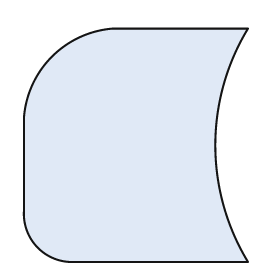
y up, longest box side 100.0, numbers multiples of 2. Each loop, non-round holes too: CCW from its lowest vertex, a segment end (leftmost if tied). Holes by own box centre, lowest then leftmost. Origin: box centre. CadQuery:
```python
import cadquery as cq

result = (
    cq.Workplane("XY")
    .moveTo(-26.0, -50.0)
    .lineTo(48.0, -50.0)
    .threePointArc((34.0, 0.0), (48.0, 50.0))
    .lineTo(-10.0, 50.0)
    .threePointArc((-36.0, 38.0), (-48.0, 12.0))
    .lineTo(-48.0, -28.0)
    .threePointArc((-42.0, -44.0), (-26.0, -50.0))
    .close()
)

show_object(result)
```